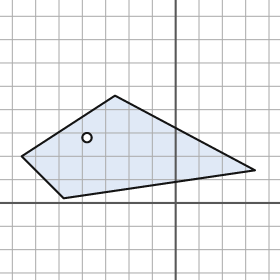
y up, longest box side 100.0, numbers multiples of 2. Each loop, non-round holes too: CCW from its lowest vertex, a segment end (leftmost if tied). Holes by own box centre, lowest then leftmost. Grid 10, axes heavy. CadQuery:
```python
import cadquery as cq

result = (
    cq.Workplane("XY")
    .moveTo(-48.0, 2.0)
    .lineTo(34.0, 14.0)
    .lineTo(-26.0, 46.0)
    .lineTo(-66.0, 20.0)
    .close()
    .moveTo(-38.0, 28.0)
    .circle(2.0)
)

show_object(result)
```